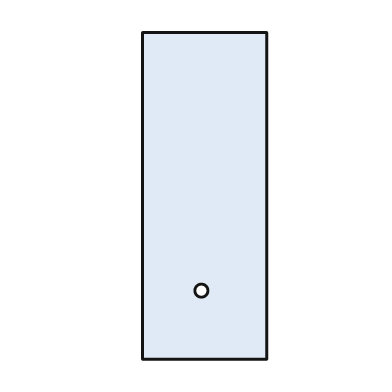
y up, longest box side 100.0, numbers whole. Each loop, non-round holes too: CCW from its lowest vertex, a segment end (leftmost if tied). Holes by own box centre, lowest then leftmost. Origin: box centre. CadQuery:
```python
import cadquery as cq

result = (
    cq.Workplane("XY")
    .moveTo(-19.0, -50.0)
    .lineTo(19.0, -50.0)
    .lineTo(19.0, 50.0)
    .lineTo(-19.0, 50.0)
    .close()
    .moveTo(-1.0, -29.0)
    .circle(2.0)
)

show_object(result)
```